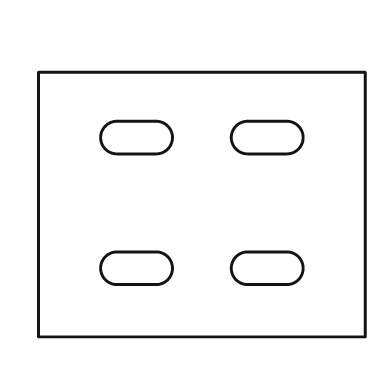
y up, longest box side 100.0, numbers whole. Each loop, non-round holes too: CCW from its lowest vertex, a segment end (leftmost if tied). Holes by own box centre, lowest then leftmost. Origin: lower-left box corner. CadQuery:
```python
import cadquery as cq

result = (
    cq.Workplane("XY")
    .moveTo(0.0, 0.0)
    .lineTo(100.0, 0.0)
    .lineTo(100.0, 81.0)
    .lineTo(0.0, 81.0)
    .close()
    .moveTo(24.0, 16.0)
    .lineTo(36.0, 16.0)
    .threePointArc((41.0, 21.0), (36.0, 26.0))
    .lineTo(24.0, 26.0)
    .threePointArc((19.0, 21.0), (24.0, 16.0))
    .close()
    .moveTo(64.0, 16.0)
    .lineTo(76.0, 16.0)
    .threePointArc((81.0, 21.0), (76.0, 26.0))
    .lineTo(64.0, 26.0)
    .threePointArc((59.0, 21.0), (64.0, 16.0))
    .close()
    .moveTo(24.0, 56.0)
    .lineTo(36.0, 56.0)
    .threePointArc((41.0, 61.0), (36.0, 66.0))
    .lineTo(24.0, 66.0)
    .threePointArc((19.0, 61.0), (24.0, 56.0))
    .close()
    .moveTo(64.0, 56.0)
    .lineTo(76.0, 56.0)
    .threePointArc((81.0, 61.0), (76.0, 66.0))
    .lineTo(64.0, 66.0)
    .threePointArc((59.0, 61.0), (64.0, 56.0))
    .close()
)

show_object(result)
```